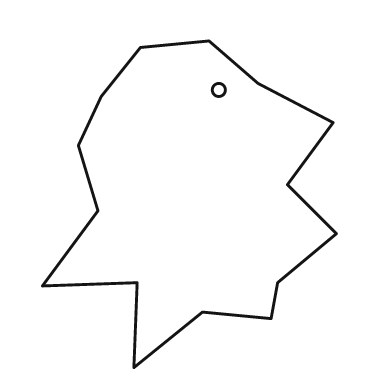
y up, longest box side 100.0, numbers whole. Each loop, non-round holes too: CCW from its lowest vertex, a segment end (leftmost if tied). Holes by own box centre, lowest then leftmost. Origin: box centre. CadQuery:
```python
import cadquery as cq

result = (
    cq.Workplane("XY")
    .moveTo(-17.0, -50.0)
    .lineTo(4.0, -33.0)
    .lineTo(25.0, -35.0)
    .lineTo(27.0, -24.0)
    .lineTo(45.0, -9.0)
    .lineTo(30.0, 6.0)
    .lineTo(44.0, 25.0)
    .lineTo(21.0, 37.0)
    .lineTo(6.0, 50.0)
    .lineTo(-15.0, 48.0)
    .lineTo(-27.0, 33.0)
    .lineTo(-34.0, 18.0)
    .lineTo(-28.0, -2.0)
    .lineTo(-45.0, -25.0)
    .lineTo(-16.0, -24.0)
    .close()
    .moveTo(9.0, 35.0)
    .circle(2.0)
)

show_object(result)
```